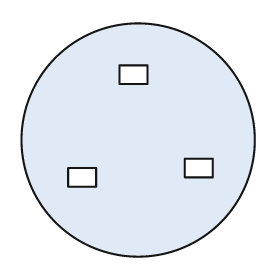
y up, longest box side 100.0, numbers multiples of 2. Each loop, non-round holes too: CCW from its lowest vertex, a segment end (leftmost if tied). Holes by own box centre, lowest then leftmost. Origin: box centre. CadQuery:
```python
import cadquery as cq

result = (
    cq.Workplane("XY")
    .moveTo(0.0, 0.0)
    .circle(50.0)
    .moveTo(-30.0, -20.0)
    .lineTo(-18.0, -20.0)
    .lineTo(-18.0, -12.0)
    .lineTo(-30.0, -12.0)
    .close()
    .moveTo(20.0, -16.0)
    .lineTo(32.0, -16.0)
    .lineTo(32.0, -8.0)
    .lineTo(20.0, -8.0)
    .close()
    .moveTo(-8.0, 24.0)
    .lineTo(4.0, 24.0)
    .lineTo(4.0, 32.0)
    .lineTo(-8.0, 32.0)
    .close()
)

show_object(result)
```